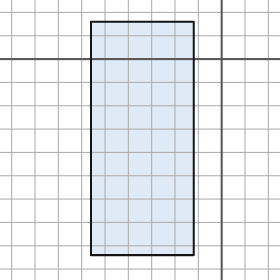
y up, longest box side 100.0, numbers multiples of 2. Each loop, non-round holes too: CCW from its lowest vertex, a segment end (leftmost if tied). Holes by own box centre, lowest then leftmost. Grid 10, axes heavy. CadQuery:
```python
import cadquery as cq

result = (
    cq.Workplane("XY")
    .moveTo(-56.0, -84.0)
    .lineTo(-12.0, -84.0)
    .lineTo(-12.0, 16.0)
    .lineTo(-56.0, 16.0)
    .close()
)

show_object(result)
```